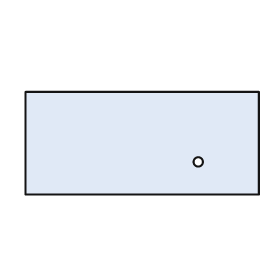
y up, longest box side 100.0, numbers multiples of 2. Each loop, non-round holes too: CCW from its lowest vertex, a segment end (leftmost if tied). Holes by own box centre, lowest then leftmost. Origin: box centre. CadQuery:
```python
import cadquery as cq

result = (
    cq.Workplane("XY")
    .moveTo(-50.0, -22.0)
    .lineTo(50.0, -22.0)
    .lineTo(50.0, 22.0)
    .lineTo(-50.0, 22.0)
    .close()
    .moveTo(24.0, -8.0)
    .circle(2.0)
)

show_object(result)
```